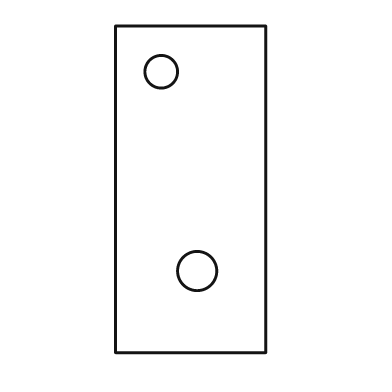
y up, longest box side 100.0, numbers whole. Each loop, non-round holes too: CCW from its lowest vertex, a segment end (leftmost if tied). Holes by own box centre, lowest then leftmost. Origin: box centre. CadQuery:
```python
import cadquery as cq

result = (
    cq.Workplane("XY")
    .moveTo(-23.0, -50.0)
    .lineTo(23.0, -50.0)
    .lineTo(23.0, 50.0)
    .lineTo(-23.0, 50.0)
    .close()
    .moveTo(2.0, -25.0)
    .circle(6.0)
    .moveTo(-9.0, 36.0)
    .circle(5.0)
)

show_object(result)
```